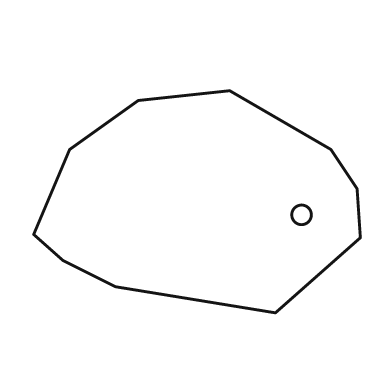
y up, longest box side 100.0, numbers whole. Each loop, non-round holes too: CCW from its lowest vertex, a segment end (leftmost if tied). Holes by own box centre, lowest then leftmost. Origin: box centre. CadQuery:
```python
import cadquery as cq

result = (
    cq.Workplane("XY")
    .moveTo(24.0, -34.0)
    .lineTo(50.0, -11.0)
    .lineTo(49.0, 4.0)
    .lineTo(41.0, 16.0)
    .lineTo(10.0, 34.0)
    .lineTo(-18.0, 31.0)
    .lineTo(-39.0, 16.0)
    .lineTo(-50.0, -10.0)
    .lineTo(-41.0, -18.0)
    .lineTo(-25.0, -26.0)
    .close()
    .moveTo(32.0, -4.0)
    .circle(3.0)
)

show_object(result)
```